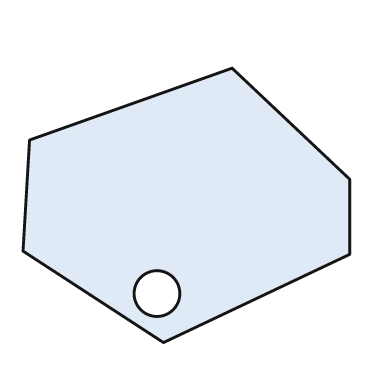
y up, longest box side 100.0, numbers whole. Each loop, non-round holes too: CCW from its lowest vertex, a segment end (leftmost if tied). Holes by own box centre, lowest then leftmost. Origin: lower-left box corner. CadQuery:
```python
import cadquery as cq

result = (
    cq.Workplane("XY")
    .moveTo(43.0, 0.0)
    .lineTo(100.0, 27.0)
    .lineTo(100.0, 50.0)
    .lineTo(64.0, 84.0)
    .lineTo(2.0, 62.0)
    .lineTo(0.0, 28.0)
    .close()
    .moveTo(41.0, 15.0)
    .circle(7.0)
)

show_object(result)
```